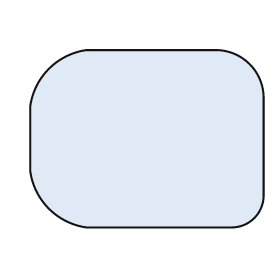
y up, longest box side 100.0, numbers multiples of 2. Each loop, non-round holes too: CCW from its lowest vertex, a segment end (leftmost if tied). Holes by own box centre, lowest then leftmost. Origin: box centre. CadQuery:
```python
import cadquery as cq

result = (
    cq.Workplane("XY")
    .moveTo(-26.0, -38.0)
    .lineTo(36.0, -38.0)
    .threePointArc((46.0, -34.0), (50.0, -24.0))
    .lineTo(50.0, 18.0)
    .threePointArc((44.0, 32.0), (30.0, 38.0))
    .lineTo(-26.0, 38.0)
    .threePointArc((-42.0, 30.0), (-50.0, 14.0))
    .lineTo(-50.0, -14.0)
    .threePointArc((-42.0, -30.0), (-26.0, -38.0))
    .close()
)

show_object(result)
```